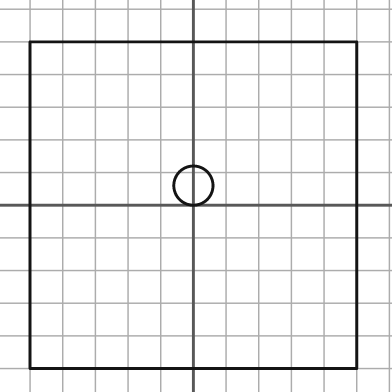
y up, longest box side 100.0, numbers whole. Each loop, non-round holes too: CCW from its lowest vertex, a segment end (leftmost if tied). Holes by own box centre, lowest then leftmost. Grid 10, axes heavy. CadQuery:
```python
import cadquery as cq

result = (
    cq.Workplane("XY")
    .moveTo(-50.0, -50.0)
    .lineTo(50.0, -50.0)
    .lineTo(50.0, 50.0)
    .lineTo(-50.0, 50.0)
    .close()
    .moveTo(0.0, 6.0)
    .circle(6.0)
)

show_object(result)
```